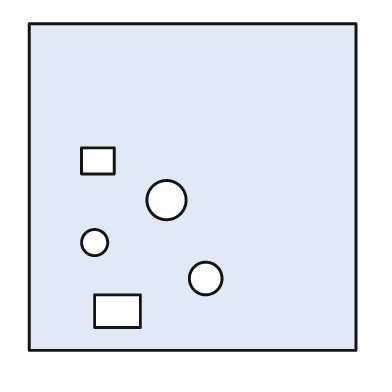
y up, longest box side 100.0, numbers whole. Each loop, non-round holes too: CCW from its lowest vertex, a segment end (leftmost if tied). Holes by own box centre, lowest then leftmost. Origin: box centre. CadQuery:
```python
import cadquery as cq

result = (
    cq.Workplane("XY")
    .moveTo(-50.0, -50.0)
    .lineTo(50.0, -50.0)
    .lineTo(50.0, 50.0)
    .lineTo(-50.0, 50.0)
    .close()
    .moveTo(-30.0, -43.0)
    .lineTo(-16.0, -43.0)
    .lineTo(-16.0, -33.0)
    .lineTo(-30.0, -33.0)
    .close()
    .moveTo(4.0, -28.0)
    .circle(5.0)
    .moveTo(-30.0, -17.0)
    .circle(4.0)
    .moveTo(-8.0, -4.0)
    .circle(6.0)
    .moveTo(-34.0, 4.0)
    .lineTo(-24.0, 4.0)
    .lineTo(-24.0, 12.0)
    .lineTo(-34.0, 12.0)
    .close()
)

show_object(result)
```